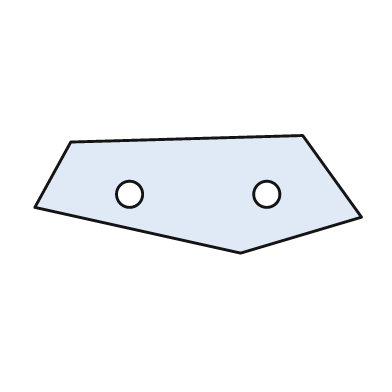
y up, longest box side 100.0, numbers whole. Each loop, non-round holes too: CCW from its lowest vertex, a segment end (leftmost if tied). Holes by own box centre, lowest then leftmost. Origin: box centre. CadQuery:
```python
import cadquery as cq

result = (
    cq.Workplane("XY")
    .moveTo(13.0, -18.0)
    .lineTo(50.0, -7.0)
    .lineTo(32.0, 18.0)
    .lineTo(-39.0, 16.0)
    .lineTo(-50.0, -4.0)
    .close()
    .moveTo(-21.0, 0.0)
    .circle(4.0)
    .moveTo(21.0, 0.0)
    .circle(4.0)
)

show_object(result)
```